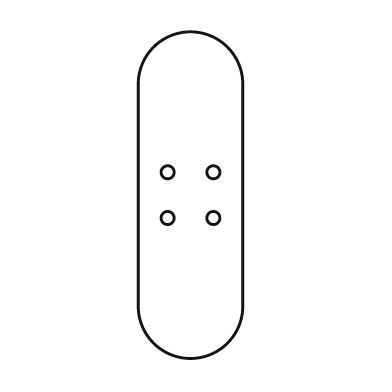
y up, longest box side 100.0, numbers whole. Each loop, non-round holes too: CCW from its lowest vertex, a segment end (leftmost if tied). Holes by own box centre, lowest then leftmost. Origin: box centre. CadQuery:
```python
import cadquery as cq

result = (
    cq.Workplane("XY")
    .moveTo(-16.0, -34.0)
    .threePointArc((0.0, -50.0), (16.0, -34.0))
    .lineTo(16.0, 34.0)
    .threePointArc((0.0, 50.0), (-16.0, 34.0))
    .close()
    .moveTo(-7.0, -7.0)
    .circle(2.0)
    .moveTo(7.0, -7.0)
    .circle(2.0)
    .moveTo(-7.0, 7.0)
    .circle(2.0)
    .moveTo(7.0, 7.0)
    .circle(2.0)
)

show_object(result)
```